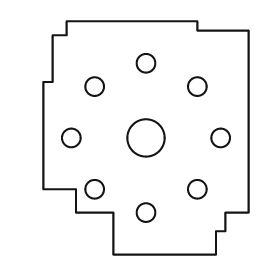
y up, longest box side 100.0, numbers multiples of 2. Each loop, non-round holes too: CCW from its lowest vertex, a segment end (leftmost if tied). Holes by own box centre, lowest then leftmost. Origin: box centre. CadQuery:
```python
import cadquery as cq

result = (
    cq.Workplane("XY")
    .moveTo(-14.0, -50.0)
    .lineTo(30.0, -50.0)
    .lineTo(30.0, -40.0)
    .lineTo(34.0, -40.0)
    .lineTo(34.0, -32.0)
    .lineTo(44.0, -32.0)
    .lineTo(44.0, 46.0)
    .lineTo(22.0, 46.0)
    .lineTo(22.0, 50.0)
    .lineTo(-34.0, 50.0)
    .lineTo(-34.0, 44.0)
    .lineTo(-40.0, 44.0)
    .lineTo(-40.0, 24.0)
    .lineTo(-44.0, 24.0)
    .lineTo(-44.0, -22.0)
    .lineTo(-30.0, -22.0)
    .lineTo(-30.0, -32.0)
    .lineTo(-14.0, -32.0)
    .close()
    .moveTo(0.0, -32.0)
    .circle(4.0)
    .moveTo(-22.0, -22.0)
    .circle(4.0)
    .moveTo(22.0, -22.0)
    .circle(4.0)
    .moveTo(-32.0, 0.0)
    .circle(4.0)
    .moveTo(0.0, 0.0)
    .circle(8.0)
    .moveTo(32.0, 0.0)
    .circle(4.0)
    .moveTo(-22.0, 22.0)
    .circle(4.0)
    .moveTo(22.0, 22.0)
    .circle(4.0)
    .moveTo(0.0, 32.0)
    .circle(4.0)
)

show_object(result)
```